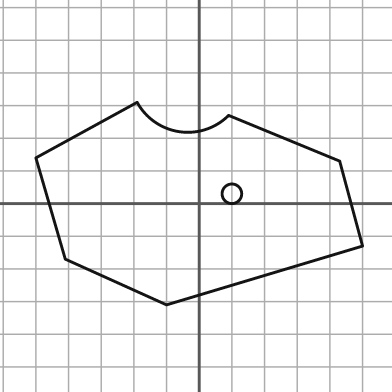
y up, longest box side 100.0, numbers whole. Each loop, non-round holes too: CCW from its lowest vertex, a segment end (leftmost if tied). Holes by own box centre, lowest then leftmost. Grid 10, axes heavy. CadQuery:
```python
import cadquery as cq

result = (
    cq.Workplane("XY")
    .moveTo(-10.0, -31.0)
    .lineTo(50.0, -13.0)
    .lineTo(43.0, 13.0)
    .lineTo(9.0, 27.0)
    .threePointArc((-6.0, 22.0), (-19.0, 31.0))
    .lineTo(-50.0, 14.0)
    .lineTo(-41.0, -17.0)
    .close()
    .moveTo(10.0, 3.0)
    .circle(3.0)
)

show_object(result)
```